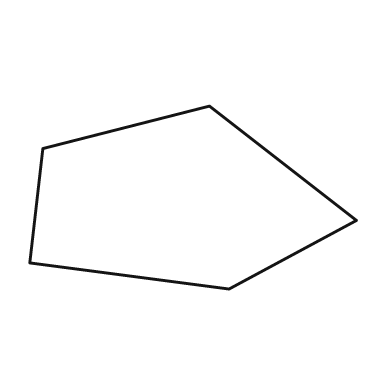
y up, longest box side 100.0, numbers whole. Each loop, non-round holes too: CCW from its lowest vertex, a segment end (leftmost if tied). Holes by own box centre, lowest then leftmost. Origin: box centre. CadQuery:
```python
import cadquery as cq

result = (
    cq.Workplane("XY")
    .moveTo(11.0, -28.0)
    .lineTo(50.0, -7.0)
    .lineTo(5.0, 28.0)
    .lineTo(-46.0, 15.0)
    .lineTo(-50.0, -20.0)
    .close()
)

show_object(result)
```